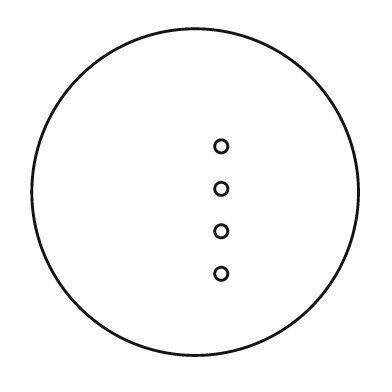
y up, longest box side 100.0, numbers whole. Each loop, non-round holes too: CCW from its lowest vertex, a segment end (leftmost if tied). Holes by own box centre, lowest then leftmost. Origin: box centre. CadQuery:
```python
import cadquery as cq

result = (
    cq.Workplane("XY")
    .moveTo(0.0, 0.0)
    .circle(50.0)
    .moveTo(8.0, -25.0)
    .circle(2.0)
    .moveTo(8.0, -12.0)
    .circle(2.0)
    .moveTo(8.0, 1.0)
    .circle(2.0)
    .moveTo(8.0, 14.0)
    .circle(2.0)
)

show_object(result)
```